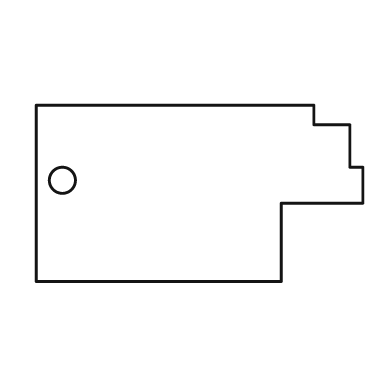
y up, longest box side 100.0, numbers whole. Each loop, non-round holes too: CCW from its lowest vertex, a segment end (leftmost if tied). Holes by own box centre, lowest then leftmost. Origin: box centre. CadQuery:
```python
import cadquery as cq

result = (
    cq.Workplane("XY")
    .moveTo(-50.0, -27.0)
    .lineTo(25.0, -27.0)
    .lineTo(25.0, -3.0)
    .lineTo(50.0, -3.0)
    .lineTo(50.0, 8.0)
    .lineTo(46.0, 8.0)
    .lineTo(46.0, 21.0)
    .lineTo(35.0, 21.0)
    .lineTo(35.0, 27.0)
    .lineTo(-50.0, 27.0)
    .close()
    .moveTo(-42.0, 4.0)
    .circle(4.0)
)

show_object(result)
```